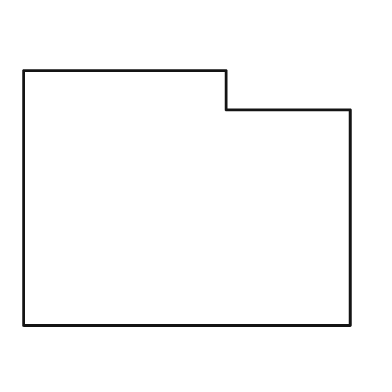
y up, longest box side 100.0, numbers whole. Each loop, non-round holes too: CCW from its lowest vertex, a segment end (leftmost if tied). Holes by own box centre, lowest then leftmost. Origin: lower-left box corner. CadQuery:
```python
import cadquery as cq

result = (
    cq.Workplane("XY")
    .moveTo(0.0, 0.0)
    .lineTo(100.0, 0.0)
    .lineTo(100.0, 66.0)
    .lineTo(62.0, 66.0)
    .lineTo(62.0, 78.0)
    .lineTo(0.0, 78.0)
    .close()
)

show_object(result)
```